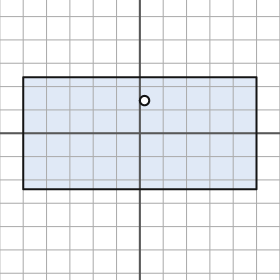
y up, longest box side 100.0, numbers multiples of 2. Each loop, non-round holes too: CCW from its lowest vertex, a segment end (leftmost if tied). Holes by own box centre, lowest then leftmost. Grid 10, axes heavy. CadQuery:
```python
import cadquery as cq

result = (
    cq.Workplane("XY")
    .moveTo(-50.0, -24.0)
    .lineTo(50.0, -24.0)
    .lineTo(50.0, 24.0)
    .lineTo(-50.0, 24.0)
    .close()
    .moveTo(2.0, 14.0)
    .circle(2.0)
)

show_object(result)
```